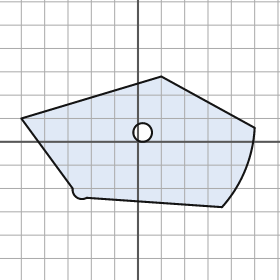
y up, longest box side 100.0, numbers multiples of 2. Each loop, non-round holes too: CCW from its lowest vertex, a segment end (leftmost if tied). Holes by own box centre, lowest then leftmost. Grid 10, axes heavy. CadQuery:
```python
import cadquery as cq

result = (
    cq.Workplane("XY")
    .moveTo(36.0, -28.0)
    .threePointArc((46.0, -12.0), (50.0, 6.0))
    .lineTo(10.0, 28.0)
    .lineTo(-50.0, 10.0)
    .lineTo(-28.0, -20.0)
    .threePointArc((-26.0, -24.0), (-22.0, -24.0))
    .close()
    .moveTo(2.0, 4.0)
    .circle(4.0)
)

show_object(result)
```